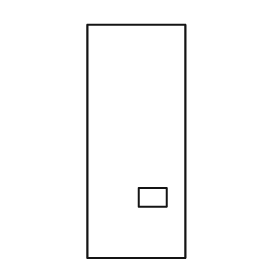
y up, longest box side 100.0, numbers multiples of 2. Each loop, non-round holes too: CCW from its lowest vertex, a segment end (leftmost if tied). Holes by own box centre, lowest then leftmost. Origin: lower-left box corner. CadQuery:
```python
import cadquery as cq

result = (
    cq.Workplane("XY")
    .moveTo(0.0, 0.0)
    .lineTo(42.0, 0.0)
    .lineTo(42.0, 100.0)
    .lineTo(0.0, 100.0)
    .close()
    .moveTo(22.0, 22.0)
    .lineTo(34.0, 22.0)
    .lineTo(34.0, 30.0)
    .lineTo(22.0, 30.0)
    .close()
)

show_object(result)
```